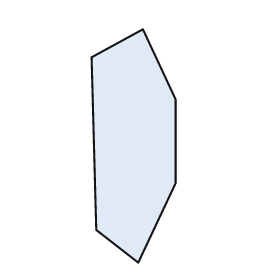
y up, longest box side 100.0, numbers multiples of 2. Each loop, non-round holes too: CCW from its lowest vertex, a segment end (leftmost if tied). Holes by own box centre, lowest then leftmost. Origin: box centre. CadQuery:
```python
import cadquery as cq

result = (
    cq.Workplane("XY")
    .moveTo(2.0, -50.0)
    .lineTo(18.0, -16.0)
    .lineTo(18.0, 20.0)
    .lineTo(4.0, 50.0)
    .lineTo(-18.0, 38.0)
    .lineTo(-16.0, -36.0)
    .close()
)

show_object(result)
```